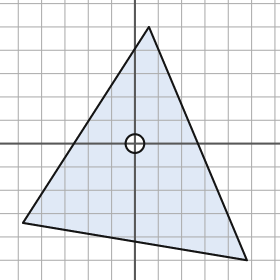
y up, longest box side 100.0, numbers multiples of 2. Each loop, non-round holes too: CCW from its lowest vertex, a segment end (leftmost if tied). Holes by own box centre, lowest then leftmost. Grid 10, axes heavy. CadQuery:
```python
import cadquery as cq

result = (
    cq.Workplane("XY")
    .moveTo(48.0, -50.0)
    .lineTo(6.0, 50.0)
    .lineTo(-48.0, -34.0)
    .close()
    .moveTo(0.0, 0.0)
    .circle(4.0)
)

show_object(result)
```